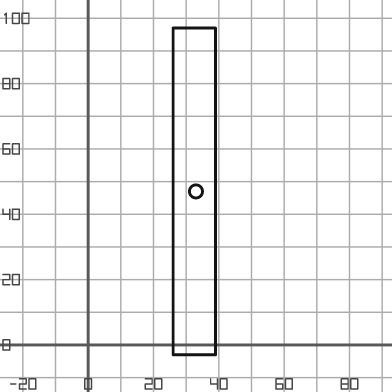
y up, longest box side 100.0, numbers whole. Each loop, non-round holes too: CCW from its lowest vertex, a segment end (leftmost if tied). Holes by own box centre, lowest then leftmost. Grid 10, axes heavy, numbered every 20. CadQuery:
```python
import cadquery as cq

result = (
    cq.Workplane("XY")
    .moveTo(26.0, -3.0)
    .lineTo(39.0, -3.0)
    .lineTo(39.0, 97.0)
    .lineTo(26.0, 97.0)
    .close()
    .moveTo(33.0, 47.0)
    .circle(2.0)
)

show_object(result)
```